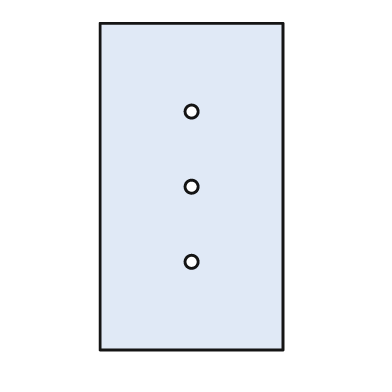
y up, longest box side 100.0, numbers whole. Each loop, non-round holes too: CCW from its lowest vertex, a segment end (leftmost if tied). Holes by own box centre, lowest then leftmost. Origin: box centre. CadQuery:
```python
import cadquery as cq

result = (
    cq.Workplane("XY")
    .moveTo(-28.0, -50.0)
    .lineTo(28.0, -50.0)
    .lineTo(28.0, 50.0)
    .lineTo(-28.0, 50.0)
    .close()
    .moveTo(0.0, -23.0)
    .circle(2.0)
    .moveTo(0.0, 0.0)
    .circle(2.0)
    .moveTo(0.0, 23.0)
    .circle(2.0)
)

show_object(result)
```